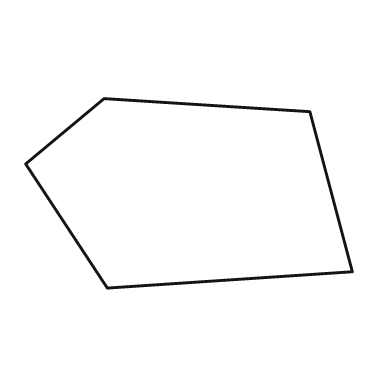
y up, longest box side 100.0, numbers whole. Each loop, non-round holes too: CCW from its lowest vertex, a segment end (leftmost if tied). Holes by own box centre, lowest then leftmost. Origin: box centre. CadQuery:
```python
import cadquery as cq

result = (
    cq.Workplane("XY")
    .moveTo(-25.0, -29.0)
    .lineTo(50.0, -24.0)
    .lineTo(37.0, 25.0)
    .lineTo(-26.0, 29.0)
    .lineTo(-50.0, 9.0)
    .close()
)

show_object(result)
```